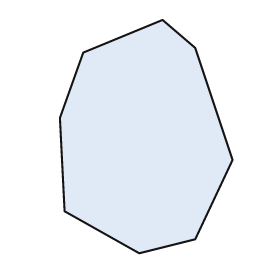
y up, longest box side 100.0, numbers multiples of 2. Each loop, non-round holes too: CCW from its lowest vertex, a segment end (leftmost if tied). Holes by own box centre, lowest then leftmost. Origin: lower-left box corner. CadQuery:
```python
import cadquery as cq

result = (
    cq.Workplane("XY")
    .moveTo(34.0, 0.0)
    .lineTo(58.0, 6.0)
    .lineTo(74.0, 40.0)
    .lineTo(58.0, 88.0)
    .lineTo(44.0, 100.0)
    .lineTo(10.0, 86.0)
    .lineTo(0.0, 58.0)
    .lineTo(2.0, 18.0)
    .close()
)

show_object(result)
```